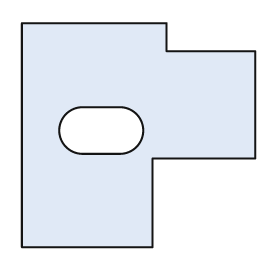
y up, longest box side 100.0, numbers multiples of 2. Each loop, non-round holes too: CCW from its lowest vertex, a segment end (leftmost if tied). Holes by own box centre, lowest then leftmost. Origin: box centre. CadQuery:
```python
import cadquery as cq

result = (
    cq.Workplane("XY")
    .moveTo(-50.0, -48.0)
    .lineTo(6.0, -48.0)
    .lineTo(6.0, -10.0)
    .lineTo(50.0, -10.0)
    .lineTo(50.0, 36.0)
    .lineTo(12.0, 36.0)
    .lineTo(12.0, 48.0)
    .lineTo(-50.0, 48.0)
    .close()
    .moveTo(-24.0, -8.0)
    .lineTo(-8.0, -8.0)
    .threePointArc((2.0, 2.0), (-8.0, 12.0))
    .lineTo(-24.0, 12.0)
    .threePointArc((-34.0, 2.0), (-24.0, -8.0))
    .close()
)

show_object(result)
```